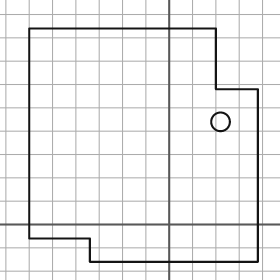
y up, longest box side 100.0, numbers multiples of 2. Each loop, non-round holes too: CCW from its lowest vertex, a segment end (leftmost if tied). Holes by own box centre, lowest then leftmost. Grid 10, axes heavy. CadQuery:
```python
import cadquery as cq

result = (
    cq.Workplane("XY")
    .moveTo(-34.0, -16.0)
    .lineTo(38.0, -16.0)
    .lineTo(38.0, 58.0)
    .lineTo(20.0, 58.0)
    .lineTo(20.0, 84.0)
    .lineTo(-60.0, 84.0)
    .lineTo(-60.0, -6.0)
    .lineTo(-34.0, -6.0)
    .close()
    .moveTo(22.0, 44.0)
    .circle(4.0)
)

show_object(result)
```